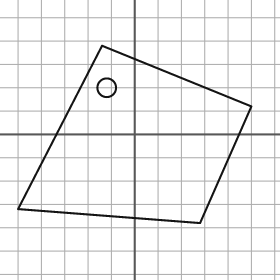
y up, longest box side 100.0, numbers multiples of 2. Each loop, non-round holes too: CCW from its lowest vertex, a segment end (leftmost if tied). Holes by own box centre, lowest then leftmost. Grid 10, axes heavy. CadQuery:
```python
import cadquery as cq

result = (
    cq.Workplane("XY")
    .moveTo(28.0, -38.0)
    .lineTo(50.0, 12.0)
    .lineTo(-14.0, 38.0)
    .lineTo(-50.0, -32.0)
    .close()
    .moveTo(-12.0, 20.0)
    .circle(4.0)
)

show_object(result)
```